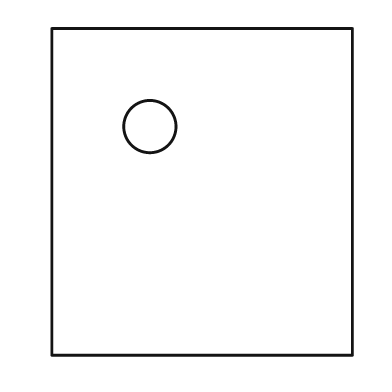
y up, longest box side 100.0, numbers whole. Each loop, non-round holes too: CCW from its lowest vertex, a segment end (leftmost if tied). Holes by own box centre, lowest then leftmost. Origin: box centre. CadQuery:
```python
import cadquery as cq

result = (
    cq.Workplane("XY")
    .moveTo(-46.0, -50.0)
    .lineTo(46.0, -50.0)
    .lineTo(46.0, 50.0)
    .lineTo(-46.0, 50.0)
    .close()
    .moveTo(-16.0, 20.0)
    .circle(8.0)
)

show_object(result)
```